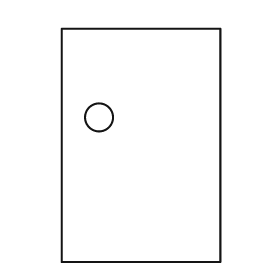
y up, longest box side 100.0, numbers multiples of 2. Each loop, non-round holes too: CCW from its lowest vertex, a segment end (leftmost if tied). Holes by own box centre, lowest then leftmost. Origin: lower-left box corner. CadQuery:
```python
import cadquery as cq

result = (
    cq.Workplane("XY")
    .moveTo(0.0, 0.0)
    .lineTo(68.0, 0.0)
    .lineTo(68.0, 100.0)
    .lineTo(0.0, 100.0)
    .close()
    .moveTo(16.0, 62.0)
    .circle(6.0)
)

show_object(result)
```